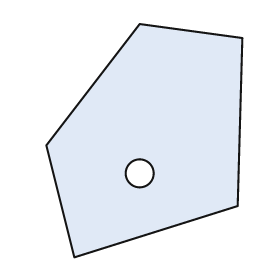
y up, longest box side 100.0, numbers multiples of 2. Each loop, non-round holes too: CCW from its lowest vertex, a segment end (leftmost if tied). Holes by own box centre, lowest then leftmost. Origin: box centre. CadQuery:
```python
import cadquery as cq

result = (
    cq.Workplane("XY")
    .moveTo(-30.0, -50.0)
    .lineTo(40.0, -28.0)
    .lineTo(42.0, 44.0)
    .lineTo(-2.0, 50.0)
    .lineTo(-42.0, -2.0)
    .close()
    .moveTo(-2.0, -14.0)
    .circle(6.0)
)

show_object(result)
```